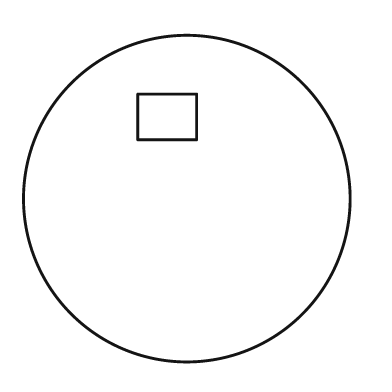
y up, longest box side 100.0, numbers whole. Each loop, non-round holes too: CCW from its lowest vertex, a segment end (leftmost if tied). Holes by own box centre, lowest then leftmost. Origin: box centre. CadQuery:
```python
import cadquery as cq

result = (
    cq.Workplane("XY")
    .moveTo(0.0, 0.0)
    .circle(50.0)
    .moveTo(-15.0, 18.0)
    .lineTo(3.0, 18.0)
    .lineTo(3.0, 32.0)
    .lineTo(-15.0, 32.0)
    .close()
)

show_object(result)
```